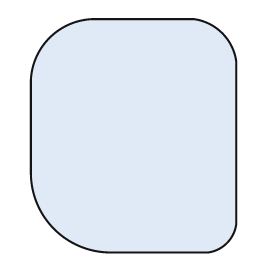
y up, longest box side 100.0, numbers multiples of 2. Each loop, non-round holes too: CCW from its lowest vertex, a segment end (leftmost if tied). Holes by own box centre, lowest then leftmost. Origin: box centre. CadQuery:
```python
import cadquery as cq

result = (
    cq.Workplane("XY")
    .moveTo(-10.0, -50.0)
    .lineTo(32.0, -50.0)
    .threePointArc((40.0, -46.0), (44.0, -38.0))
    .lineTo(44.0, 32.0)
    .threePointArc((38.0, 44.0), (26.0, 50.0))
    .lineTo(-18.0, 50.0)
    .threePointArc((-36.0, 42.0), (-44.0, 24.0))
    .lineTo(-44.0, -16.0)
    .threePointArc((-34.0, -40.0), (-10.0, -50.0))
    .close()
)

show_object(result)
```